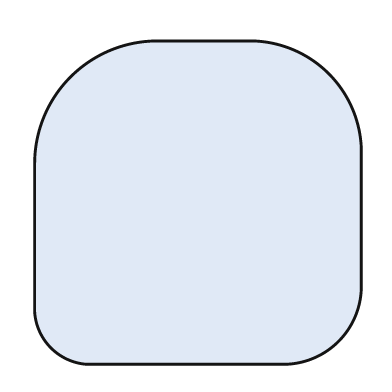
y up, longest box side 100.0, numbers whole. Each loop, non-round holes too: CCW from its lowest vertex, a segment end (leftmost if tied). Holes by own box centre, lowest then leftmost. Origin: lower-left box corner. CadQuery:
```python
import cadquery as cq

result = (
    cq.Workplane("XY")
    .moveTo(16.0, 0.0)
    .lineTo(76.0, 0.0)
    .threePointArc((93.0, 7.0), (100.0, 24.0))
    .lineTo(100.0, 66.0)
    .threePointArc((90.0, 89.0), (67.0, 99.0))
    .lineTo(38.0, 99.0)
    .threePointArc((11.0, 88.0), (0.0, 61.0))
    .lineTo(0.0, 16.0)
    .threePointArc((5.0, 5.0), (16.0, 0.0))
    .close()
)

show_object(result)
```